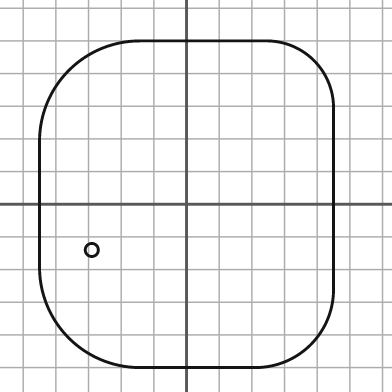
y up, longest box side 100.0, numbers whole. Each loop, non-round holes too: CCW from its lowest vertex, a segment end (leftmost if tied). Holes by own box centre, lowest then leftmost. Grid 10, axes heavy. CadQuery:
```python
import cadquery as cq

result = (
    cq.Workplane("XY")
    .moveTo(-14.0, -50.0)
    .lineTo(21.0, -50.0)
    .threePointArc((38.0, -43.0), (45.0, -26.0))
    .lineTo(45.0, 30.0)
    .threePointArc((39.0, 44.0), (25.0, 50.0))
    .lineTo(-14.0, 50.0)
    .threePointArc((-36.0, 41.0), (-45.0, 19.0))
    .lineTo(-45.0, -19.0)
    .threePointArc((-36.0, -41.0), (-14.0, -50.0))
    .close()
    .moveTo(-29.0, -14.0)
    .circle(2.0)
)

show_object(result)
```